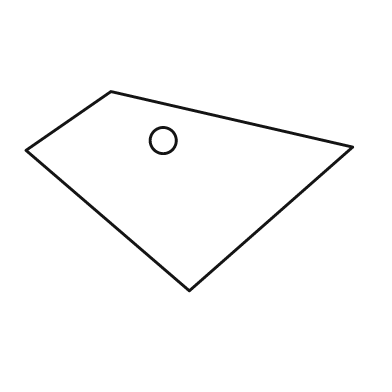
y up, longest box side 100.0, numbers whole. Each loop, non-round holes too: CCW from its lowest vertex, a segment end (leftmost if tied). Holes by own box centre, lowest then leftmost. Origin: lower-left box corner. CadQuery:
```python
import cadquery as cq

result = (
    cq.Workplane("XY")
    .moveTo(50.0, 0.0)
    .lineTo(100.0, 44.0)
    .lineTo(26.0, 61.0)
    .lineTo(0.0, 43.0)
    .close()
    .moveTo(42.0, 46.0)
    .circle(4.0)
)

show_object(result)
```